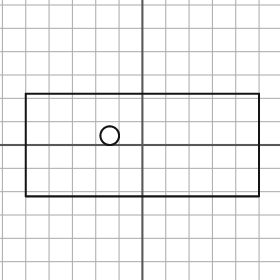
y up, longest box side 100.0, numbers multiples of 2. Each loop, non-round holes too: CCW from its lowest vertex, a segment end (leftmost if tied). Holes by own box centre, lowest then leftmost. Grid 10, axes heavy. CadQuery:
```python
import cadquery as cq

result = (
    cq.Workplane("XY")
    .moveTo(-50.0, -22.0)
    .lineTo(50.0, -22.0)
    .lineTo(50.0, 22.0)
    .lineTo(-50.0, 22.0)
    .close()
    .moveTo(-14.0, 4.0)
    .circle(4.0)
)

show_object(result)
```